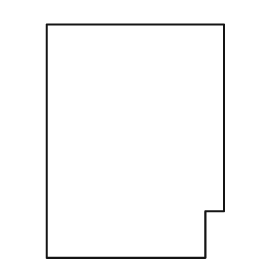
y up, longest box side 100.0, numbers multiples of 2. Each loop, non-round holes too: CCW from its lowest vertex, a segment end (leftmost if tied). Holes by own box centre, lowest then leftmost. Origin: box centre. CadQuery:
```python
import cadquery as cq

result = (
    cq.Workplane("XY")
    .moveTo(-38.0, -50.0)
    .lineTo(30.0, -50.0)
    .lineTo(30.0, -30.0)
    .lineTo(38.0, -30.0)
    .lineTo(38.0, 50.0)
    .lineTo(-38.0, 50.0)
    .close()
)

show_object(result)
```